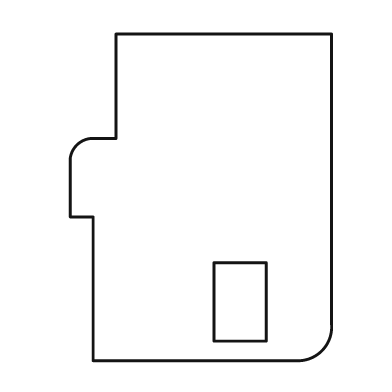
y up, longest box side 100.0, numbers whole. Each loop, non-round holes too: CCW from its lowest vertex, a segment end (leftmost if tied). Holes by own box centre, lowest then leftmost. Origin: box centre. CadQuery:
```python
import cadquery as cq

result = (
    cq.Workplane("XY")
    .moveTo(-33.0, -50.0)
    .lineTo(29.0, -50.0)
    .threePointArc((37.0, -47.0), (40.0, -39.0))
    .lineTo(40.0, 50.0)
    .lineTo(-26.0, 50.0)
    .lineTo(-26.0, 18.0)
    .lineTo(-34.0, 18.0)
    .threePointArc((-38.0, 16.0), (-40.0, 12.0))
    .lineTo(-40.0, -6.0)
    .lineTo(-33.0, -6.0)
    .close()
    .moveTo(4.0, -44.0)
    .lineTo(20.0, -44.0)
    .lineTo(20.0, -20.0)
    .lineTo(4.0, -20.0)
    .close()
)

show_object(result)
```